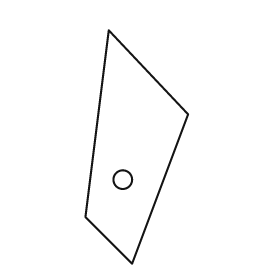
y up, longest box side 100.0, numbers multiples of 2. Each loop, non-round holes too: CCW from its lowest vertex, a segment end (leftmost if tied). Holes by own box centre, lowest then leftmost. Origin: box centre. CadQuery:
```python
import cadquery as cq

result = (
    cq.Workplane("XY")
    .moveTo(-2.0, -50.0)
    .lineTo(22.0, 14.0)
    .lineTo(-12.0, 50.0)
    .lineTo(-22.0, -30.0)
    .close()
    .moveTo(-6.0, -14.0)
    .circle(4.0)
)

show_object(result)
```